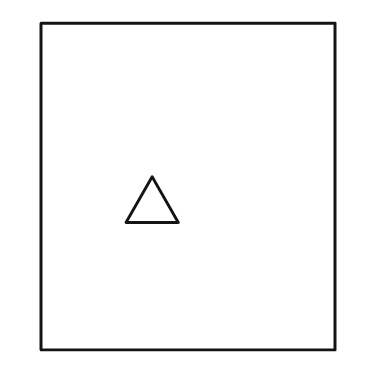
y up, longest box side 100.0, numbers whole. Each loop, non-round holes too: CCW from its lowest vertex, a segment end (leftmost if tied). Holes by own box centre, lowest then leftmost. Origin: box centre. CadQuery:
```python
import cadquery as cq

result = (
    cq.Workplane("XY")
    .moveTo(-45.0, -50.0)
    .lineTo(45.0, -50.0)
    .lineTo(45.0, 50.0)
    .lineTo(-45.0, 50.0)
    .close()
    .moveTo(-19.0, -11.0)
    .lineTo(-3.0, -11.0)
    .lineTo(-11.0, 3.0)
    .close()
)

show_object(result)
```